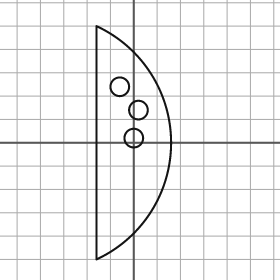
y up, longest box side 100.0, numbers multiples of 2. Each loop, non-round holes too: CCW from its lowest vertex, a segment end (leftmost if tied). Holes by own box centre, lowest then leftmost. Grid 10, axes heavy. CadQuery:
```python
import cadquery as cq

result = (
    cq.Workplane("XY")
    .moveTo(-16.0, -50.0)
    .threePointArc((16.0, 0.0), (-16.0, 50.0))
    .close()
    .moveTo(0.0, 2.0)
    .circle(4.0)
    .moveTo(2.0, 14.0)
    .circle(4.0)
    .moveTo(-6.0, 24.0)
    .circle(4.0)
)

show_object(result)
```